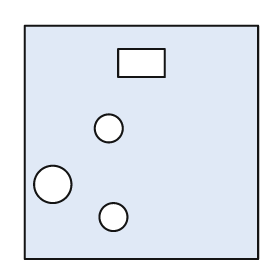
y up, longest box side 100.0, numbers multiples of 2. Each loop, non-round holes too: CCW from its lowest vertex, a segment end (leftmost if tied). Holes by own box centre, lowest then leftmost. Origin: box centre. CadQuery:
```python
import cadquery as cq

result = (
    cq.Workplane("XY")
    .moveTo(-50.0, -50.0)
    .lineTo(50.0, -50.0)
    .lineTo(50.0, 50.0)
    .lineTo(-50.0, 50.0)
    .close()
    .moveTo(-12.0, -32.0)
    .circle(6.0)
    .moveTo(-38.0, -18.0)
    .circle(8.0)
    .moveTo(-14.0, 6.0)
    .circle(6.0)
    .moveTo(-10.0, 28.0)
    .lineTo(10.0, 28.0)
    .lineTo(10.0, 40.0)
    .lineTo(-10.0, 40.0)
    .close()
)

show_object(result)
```